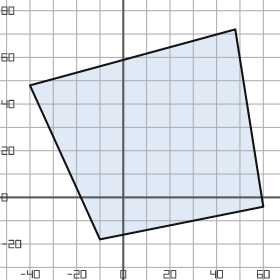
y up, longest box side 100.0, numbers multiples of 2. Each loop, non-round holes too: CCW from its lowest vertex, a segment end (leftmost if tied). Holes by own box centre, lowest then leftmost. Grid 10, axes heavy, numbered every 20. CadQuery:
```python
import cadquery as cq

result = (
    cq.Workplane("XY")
    .moveTo(-10.0, -18.0)
    .lineTo(60.0, -4.0)
    .lineTo(48.0, 72.0)
    .lineTo(-40.0, 48.0)
    .close()
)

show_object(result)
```